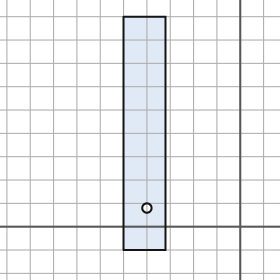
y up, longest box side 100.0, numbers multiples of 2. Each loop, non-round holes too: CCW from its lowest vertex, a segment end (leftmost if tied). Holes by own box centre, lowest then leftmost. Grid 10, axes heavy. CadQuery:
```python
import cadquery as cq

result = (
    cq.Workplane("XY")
    .moveTo(-50.0, -10.0)
    .lineTo(-32.0, -10.0)
    .lineTo(-32.0, 90.0)
    .lineTo(-50.0, 90.0)
    .close()
    .moveTo(-40.0, 8.0)
    .circle(2.0)
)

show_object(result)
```